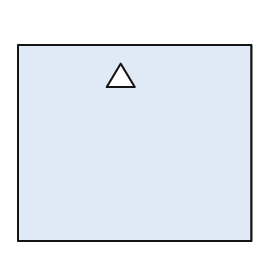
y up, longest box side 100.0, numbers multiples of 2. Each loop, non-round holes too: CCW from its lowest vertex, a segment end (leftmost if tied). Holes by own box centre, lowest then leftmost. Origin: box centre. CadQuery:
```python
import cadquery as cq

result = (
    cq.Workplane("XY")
    .moveTo(-50.0, -42.0)
    .lineTo(50.0, -42.0)
    .lineTo(50.0, 42.0)
    .lineTo(-50.0, 42.0)
    .close()
    .moveTo(-12.0, 24.0)
    .lineTo(0.0, 24.0)
    .lineTo(-6.0, 34.0)
    .close()
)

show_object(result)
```